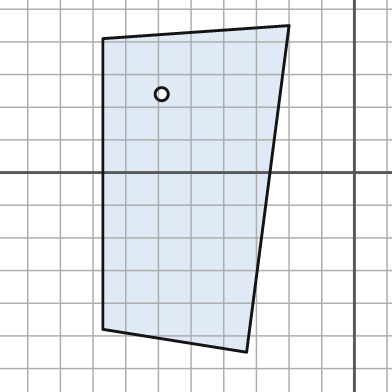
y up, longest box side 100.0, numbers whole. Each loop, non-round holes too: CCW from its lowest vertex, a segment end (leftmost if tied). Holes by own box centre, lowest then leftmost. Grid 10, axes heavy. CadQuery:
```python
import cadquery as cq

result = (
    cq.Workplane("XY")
    .moveTo(-33.0, -55.0)
    .lineTo(-20.0, 45.0)
    .lineTo(-77.0, 41.0)
    .lineTo(-77.0, -48.0)
    .close()
    .moveTo(-59.0, 24.0)
    .circle(2.0)
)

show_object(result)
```